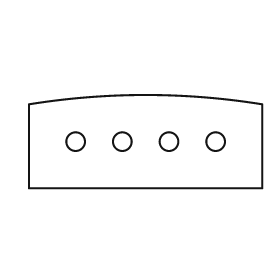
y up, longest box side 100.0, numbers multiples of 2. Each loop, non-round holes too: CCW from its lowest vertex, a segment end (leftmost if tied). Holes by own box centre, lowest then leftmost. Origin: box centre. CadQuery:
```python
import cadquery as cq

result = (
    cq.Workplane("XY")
    .moveTo(-50.0, -20.0)
    .lineTo(50.0, -20.0)
    .lineTo(50.0, 16.0)
    .threePointArc((0.0, 20.0), (-50.0, 16.0))
    .close()
    .moveTo(-30.0, 0.0)
    .circle(4.0)
    .moveTo(-10.0, 0.0)
    .circle(4.0)
    .moveTo(10.0, 0.0)
    .circle(4.0)
    .moveTo(30.0, 0.0)
    .circle(4.0)
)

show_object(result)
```